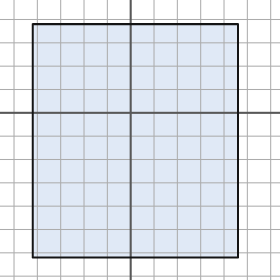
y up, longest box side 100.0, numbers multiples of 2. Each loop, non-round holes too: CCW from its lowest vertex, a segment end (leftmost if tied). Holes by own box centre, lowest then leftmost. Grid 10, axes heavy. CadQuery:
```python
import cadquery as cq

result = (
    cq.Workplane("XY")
    .moveTo(-42.0, -62.0)
    .lineTo(46.0, -62.0)
    .lineTo(46.0, 38.0)
    .lineTo(-42.0, 38.0)
    .close()
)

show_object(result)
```